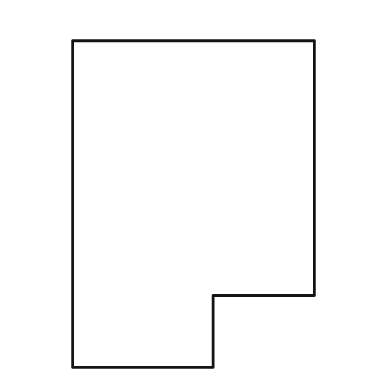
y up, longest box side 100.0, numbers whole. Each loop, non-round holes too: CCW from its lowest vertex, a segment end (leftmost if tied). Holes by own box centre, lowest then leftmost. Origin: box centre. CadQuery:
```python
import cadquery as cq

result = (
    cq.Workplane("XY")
    .moveTo(-37.0, -50.0)
    .lineTo(6.0, -50.0)
    .lineTo(6.0, -28.0)
    .lineTo(37.0, -28.0)
    .lineTo(37.0, 50.0)
    .lineTo(-37.0, 50.0)
    .close()
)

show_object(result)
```